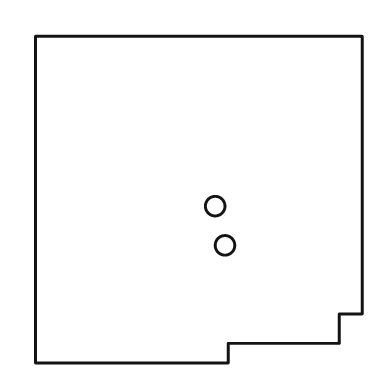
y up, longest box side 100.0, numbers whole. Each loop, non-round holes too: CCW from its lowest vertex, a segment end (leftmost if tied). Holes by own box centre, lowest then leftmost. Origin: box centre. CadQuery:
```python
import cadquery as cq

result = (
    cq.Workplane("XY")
    .moveTo(-50.0, -50.0)
    .lineTo(9.0, -50.0)
    .lineTo(9.0, -44.0)
    .lineTo(43.0, -44.0)
    .lineTo(43.0, -35.0)
    .lineTo(50.0, -35.0)
    .lineTo(50.0, 50.0)
    .lineTo(-50.0, 50.0)
    .close()
    .moveTo(8.0, -14.0)
    .circle(3.0)
    .moveTo(5.0, -2.0)
    .circle(3.0)
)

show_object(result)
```